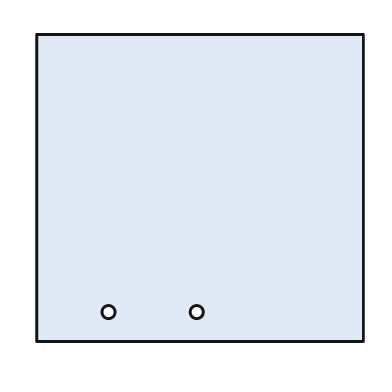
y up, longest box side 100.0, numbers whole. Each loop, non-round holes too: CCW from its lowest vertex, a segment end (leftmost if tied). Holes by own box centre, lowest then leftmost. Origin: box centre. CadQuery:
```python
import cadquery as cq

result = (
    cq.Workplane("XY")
    .moveTo(-50.0, -47.0)
    .lineTo(50.0, -47.0)
    .lineTo(50.0, 47.0)
    .lineTo(-50.0, 47.0)
    .close()
    .moveTo(-28.0, -38.0)
    .circle(2.0)
    .moveTo(-1.0, -38.0)
    .circle(2.0)
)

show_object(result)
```